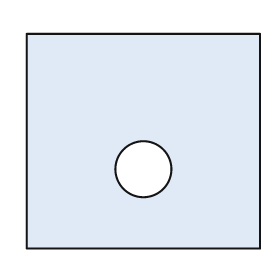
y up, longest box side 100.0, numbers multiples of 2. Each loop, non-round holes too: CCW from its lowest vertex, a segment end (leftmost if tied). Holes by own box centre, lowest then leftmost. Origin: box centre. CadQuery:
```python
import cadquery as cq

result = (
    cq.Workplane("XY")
    .moveTo(-50.0, -46.0)
    .lineTo(50.0, -46.0)
    .lineTo(50.0, 46.0)
    .lineTo(-50.0, 46.0)
    .close()
    .moveTo(0.0, -12.0)
    .circle(12.0)
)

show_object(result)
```